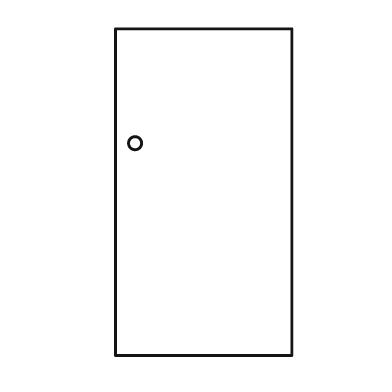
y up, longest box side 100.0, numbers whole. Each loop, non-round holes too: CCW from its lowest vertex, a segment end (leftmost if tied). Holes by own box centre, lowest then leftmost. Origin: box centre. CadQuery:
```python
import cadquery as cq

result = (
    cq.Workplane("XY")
    .moveTo(-27.0, -50.0)
    .lineTo(27.0, -50.0)
    .lineTo(27.0, 50.0)
    .lineTo(-27.0, 50.0)
    .close()
    .moveTo(-21.0, 15.0)
    .circle(2.0)
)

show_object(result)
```